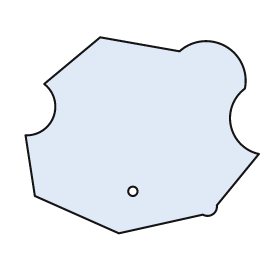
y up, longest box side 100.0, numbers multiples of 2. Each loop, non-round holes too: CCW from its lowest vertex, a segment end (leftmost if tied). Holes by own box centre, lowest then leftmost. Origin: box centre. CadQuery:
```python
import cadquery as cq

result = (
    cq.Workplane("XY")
    .moveTo(-10.0, -42.0)
    .lineTo(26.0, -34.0)
    .threePointArc((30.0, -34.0), (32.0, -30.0))
    .lineTo(50.0, -8.0)
    .threePointArc((38.0, 4.0), (44.0, 20.0))
    .threePointArc((36.0, 38.0), (16.0, 36.0))
    .lineTo(-18.0, 42.0)
    .lineTo(-42.0, 22.0)
    .threePointArc((-38.0, 8.0), (-50.0, 0.0))
    .lineTo(-46.0, -26.0)
    .close()
    .moveTo(-4.0, -24.0)
    .circle(2.0)
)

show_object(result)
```